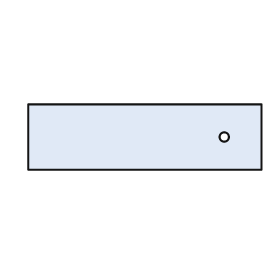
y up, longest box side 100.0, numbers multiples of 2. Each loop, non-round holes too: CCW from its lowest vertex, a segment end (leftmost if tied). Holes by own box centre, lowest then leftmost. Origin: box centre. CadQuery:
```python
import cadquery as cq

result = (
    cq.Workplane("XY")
    .moveTo(-50.0, -14.0)
    .lineTo(50.0, -14.0)
    .lineTo(50.0, 14.0)
    .lineTo(-50.0, 14.0)
    .close()
    .moveTo(34.0, 0.0)
    .circle(2.0)
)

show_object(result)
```